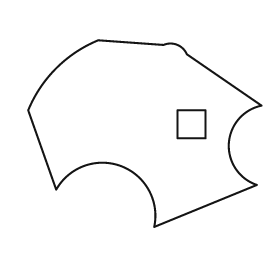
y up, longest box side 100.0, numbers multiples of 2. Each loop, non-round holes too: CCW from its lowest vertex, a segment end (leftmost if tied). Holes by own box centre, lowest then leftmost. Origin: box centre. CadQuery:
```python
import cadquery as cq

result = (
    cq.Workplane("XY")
    .moveTo(4.0, -40.0)
    .lineTo(48.0, -22.0)
    .threePointArc((36.0, -4.0), (50.0, 12.0))
    .lineTo(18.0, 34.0)
    .threePointArc((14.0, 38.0), (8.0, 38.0))
    .lineTo(-20.0, 40.0)
    .threePointArc((-38.0, 28.0), (-50.0, 10.0))
    .lineTo(-38.0, -24.0)
    .threePointArc((-10.0, -14.0), (4.0, -40.0))
    .close()
    .moveTo(14.0, -2.0)
    .lineTo(26.0, -2.0)
    .lineTo(26.0, 10.0)
    .lineTo(14.0, 10.0)
    .close()
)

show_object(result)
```